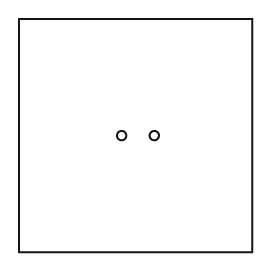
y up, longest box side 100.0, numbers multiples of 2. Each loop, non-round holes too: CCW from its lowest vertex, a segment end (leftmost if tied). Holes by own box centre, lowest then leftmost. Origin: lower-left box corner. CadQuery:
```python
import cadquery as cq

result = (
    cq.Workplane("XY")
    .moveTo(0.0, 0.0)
    .lineTo(100.0, 0.0)
    .lineTo(100.0, 100.0)
    .lineTo(0.0, 100.0)
    .close()
    .moveTo(44.0, 50.0)
    .circle(2.0)
    .moveTo(58.0, 50.0)
    .circle(2.0)
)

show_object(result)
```